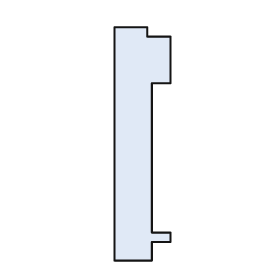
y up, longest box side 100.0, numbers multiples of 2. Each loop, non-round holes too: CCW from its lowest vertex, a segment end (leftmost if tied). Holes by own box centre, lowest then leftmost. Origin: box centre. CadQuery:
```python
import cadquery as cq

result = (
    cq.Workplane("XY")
    .moveTo(-12.0, -50.0)
    .lineTo(4.0, -50.0)
    .lineTo(4.0, -42.0)
    .lineTo(12.0, -42.0)
    .lineTo(12.0, -38.0)
    .lineTo(4.0, -38.0)
    .lineTo(4.0, 26.0)
    .lineTo(12.0, 26.0)
    .lineTo(12.0, 46.0)
    .lineTo(2.0, 46.0)
    .lineTo(2.0, 50.0)
    .lineTo(-12.0, 50.0)
    .close()
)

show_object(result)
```